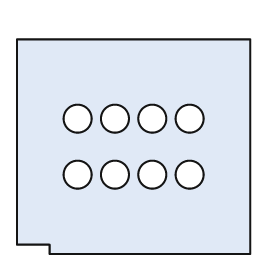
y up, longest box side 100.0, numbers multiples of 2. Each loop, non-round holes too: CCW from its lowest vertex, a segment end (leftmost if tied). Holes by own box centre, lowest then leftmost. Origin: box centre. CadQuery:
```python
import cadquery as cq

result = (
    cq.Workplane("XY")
    .moveTo(-36.0, -46.0)
    .lineTo(50.0, -46.0)
    .lineTo(50.0, 46.0)
    .lineTo(-50.0, 46.0)
    .lineTo(-50.0, -42.0)
    .lineTo(-36.0, -42.0)
    .close()
    .moveTo(-24.0, -12.0)
    .circle(6.0)
    .moveTo(-8.0, -12.0)
    .circle(6.0)
    .moveTo(8.0, -12.0)
    .circle(6.0)
    .moveTo(24.0, -12.0)
    .circle(6.0)
    .moveTo(-24.0, 12.0)
    .circle(6.0)
    .moveTo(-8.0, 12.0)
    .circle(6.0)
    .moveTo(8.0, 12.0)
    .circle(6.0)
    .moveTo(24.0, 12.0)
    .circle(6.0)
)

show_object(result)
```